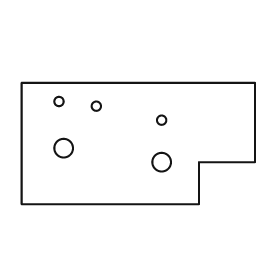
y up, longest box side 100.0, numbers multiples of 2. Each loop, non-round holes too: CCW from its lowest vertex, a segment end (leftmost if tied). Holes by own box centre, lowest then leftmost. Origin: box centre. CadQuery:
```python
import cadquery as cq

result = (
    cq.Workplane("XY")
    .moveTo(-50.0, -26.0)
    .lineTo(26.0, -26.0)
    .lineTo(26.0, -8.0)
    .lineTo(50.0, -8.0)
    .lineTo(50.0, 26.0)
    .lineTo(-50.0, 26.0)
    .close()
    .moveTo(10.0, -8.0)
    .circle(4.0)
    .moveTo(-32.0, -2.0)
    .circle(4.0)
    .moveTo(10.0, 10.0)
    .circle(2.0)
    .moveTo(-18.0, 16.0)
    .circle(2.0)
    .moveTo(-34.0, 18.0)
    .circle(2.0)
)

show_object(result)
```